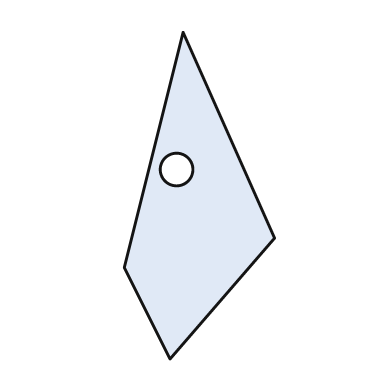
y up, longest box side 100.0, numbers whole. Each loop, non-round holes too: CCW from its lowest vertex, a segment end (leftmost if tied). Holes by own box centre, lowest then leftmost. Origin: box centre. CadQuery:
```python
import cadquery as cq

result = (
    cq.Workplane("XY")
    .moveTo(-9.0, -50.0)
    .lineTo(23.0, -13.0)
    .lineTo(-5.0, 50.0)
    .lineTo(-23.0, -22.0)
    .close()
    .moveTo(-7.0, 8.0)
    .circle(5.0)
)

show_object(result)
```